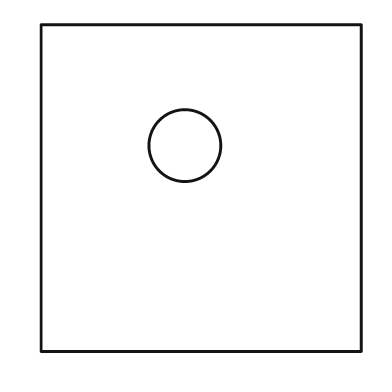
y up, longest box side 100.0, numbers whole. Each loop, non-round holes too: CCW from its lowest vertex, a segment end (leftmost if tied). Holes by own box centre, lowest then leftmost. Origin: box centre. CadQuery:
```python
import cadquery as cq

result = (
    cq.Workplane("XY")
    .moveTo(-49.0, -50.0)
    .lineTo(49.0, -50.0)
    .lineTo(49.0, 50.0)
    .lineTo(-49.0, 50.0)
    .close()
    .moveTo(-5.0, 13.0)
    .circle(11.0)
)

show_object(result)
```